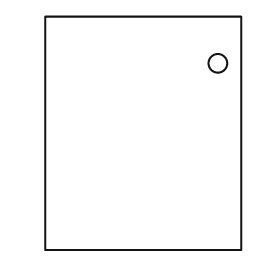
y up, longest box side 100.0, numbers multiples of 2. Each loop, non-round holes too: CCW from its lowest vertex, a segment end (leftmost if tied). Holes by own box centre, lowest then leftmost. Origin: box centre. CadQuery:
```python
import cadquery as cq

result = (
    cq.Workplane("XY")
    .moveTo(-42.0, -50.0)
    .lineTo(42.0, -50.0)
    .lineTo(42.0, 50.0)
    .lineTo(-42.0, 50.0)
    .close()
    .moveTo(32.0, 30.0)
    .circle(4.0)
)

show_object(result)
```